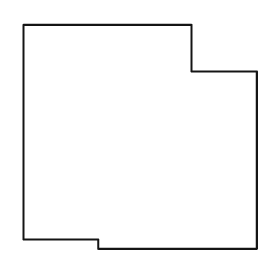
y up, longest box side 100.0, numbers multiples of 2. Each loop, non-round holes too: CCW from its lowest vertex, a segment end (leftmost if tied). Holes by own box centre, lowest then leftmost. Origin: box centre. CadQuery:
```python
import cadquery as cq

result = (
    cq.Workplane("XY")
    .moveTo(-18.0, -48.0)
    .lineTo(50.0, -48.0)
    .lineTo(50.0, 28.0)
    .lineTo(22.0, 28.0)
    .lineTo(22.0, 48.0)
    .lineTo(-50.0, 48.0)
    .lineTo(-50.0, -44.0)
    .lineTo(-18.0, -44.0)
    .close()
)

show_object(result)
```